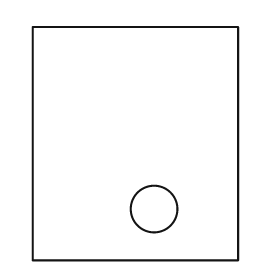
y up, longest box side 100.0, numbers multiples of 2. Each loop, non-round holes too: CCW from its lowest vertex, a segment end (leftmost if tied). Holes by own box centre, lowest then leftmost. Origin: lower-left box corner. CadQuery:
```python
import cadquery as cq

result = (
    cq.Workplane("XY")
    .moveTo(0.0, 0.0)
    .lineTo(88.0, 0.0)
    .lineTo(88.0, 100.0)
    .lineTo(0.0, 100.0)
    .close()
    .moveTo(52.0, 22.0)
    .circle(10.0)
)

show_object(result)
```